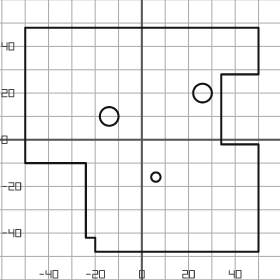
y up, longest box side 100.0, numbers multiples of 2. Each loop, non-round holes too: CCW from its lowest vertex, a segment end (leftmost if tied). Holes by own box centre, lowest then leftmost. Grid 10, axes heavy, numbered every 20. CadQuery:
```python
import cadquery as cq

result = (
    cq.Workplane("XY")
    .moveTo(-20.0, -48.0)
    .lineTo(50.0, -48.0)
    .lineTo(50.0, -2.0)
    .lineTo(34.0, -2.0)
    .lineTo(34.0, 28.0)
    .lineTo(50.0, 28.0)
    .lineTo(50.0, 48.0)
    .lineTo(-50.0, 48.0)
    .lineTo(-50.0, -10.0)
    .lineTo(-24.0, -10.0)
    .lineTo(-24.0, -42.0)
    .lineTo(-20.0, -42.0)
    .close()
    .moveTo(6.0, -16.0)
    .circle(2.0)
    .moveTo(-14.0, 10.0)
    .circle(4.0)
    .moveTo(26.0, 20.0)
    .circle(4.0)
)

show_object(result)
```